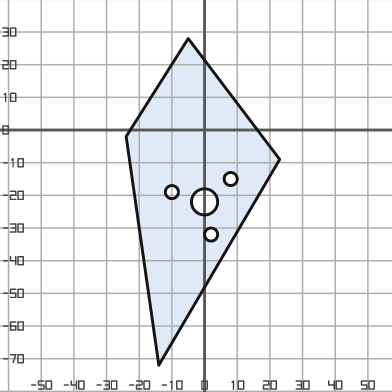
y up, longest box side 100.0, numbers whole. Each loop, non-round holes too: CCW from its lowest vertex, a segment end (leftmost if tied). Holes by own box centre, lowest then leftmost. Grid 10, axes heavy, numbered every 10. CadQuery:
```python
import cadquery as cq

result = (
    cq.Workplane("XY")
    .moveTo(-14.0, -72.0)
    .lineTo(23.0, -9.0)
    .lineTo(-5.0, 28.0)
    .lineTo(-24.0, -2.0)
    .close()
    .moveTo(2.0, -32.0)
    .circle(2.0)
    .moveTo(0.0, -22.0)
    .circle(4.0)
    .moveTo(-10.0, -19.0)
    .circle(2.0)
    .moveTo(8.0, -15.0)
    .circle(2.0)
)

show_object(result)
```